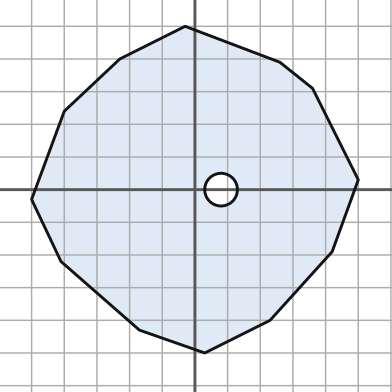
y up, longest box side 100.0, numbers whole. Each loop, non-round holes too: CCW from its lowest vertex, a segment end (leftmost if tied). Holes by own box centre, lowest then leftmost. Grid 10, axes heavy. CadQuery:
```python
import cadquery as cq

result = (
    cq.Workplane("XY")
    .moveTo(3.0, -50.0)
    .lineTo(23.0, -40.0)
    .lineTo(42.0, -19.0)
    .lineTo(50.0, 3.0)
    .lineTo(36.0, 31.0)
    .lineTo(26.0, 39.0)
    .lineTo(-3.0, 50.0)
    .lineTo(-23.0, 40.0)
    .lineTo(-40.0, 24.0)
    .lineTo(-50.0, -3.0)
    .lineTo(-41.0, -22.0)
    .lineTo(-17.0, -43.0)
    .close()
    .moveTo(8.0, 0.0)
    .circle(5.0)
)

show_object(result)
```